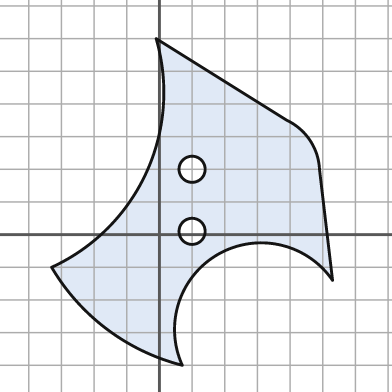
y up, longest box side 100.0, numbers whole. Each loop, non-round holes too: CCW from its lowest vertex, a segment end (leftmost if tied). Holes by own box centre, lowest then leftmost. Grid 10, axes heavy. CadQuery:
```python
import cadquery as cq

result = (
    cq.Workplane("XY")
    .moveTo(7.0, -40.0)
    .threePointArc((18.0, -6.0), (53.0, -14.0))
    .lineTo(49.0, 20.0)
    .threePointArc((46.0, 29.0), (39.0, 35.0))
    .lineTo(-1.0, 60.0)
    .threePointArc((-4.0, 19.0), (-33.0, -10.0))
    .threePointArc((-16.0, -29.0), (7.0, -40.0))
    .close()
    .moveTo(10.0, 1.0)
    .circle(4.0)
    .moveTo(10.0, 20.0)
    .circle(4.0)
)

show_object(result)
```